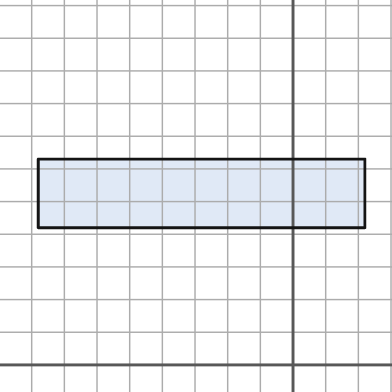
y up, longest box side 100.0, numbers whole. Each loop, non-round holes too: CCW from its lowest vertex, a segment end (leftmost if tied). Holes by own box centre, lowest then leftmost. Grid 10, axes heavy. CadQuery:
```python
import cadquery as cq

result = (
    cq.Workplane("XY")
    .moveTo(-78.0, 42.0)
    .lineTo(22.0, 42.0)
    .lineTo(22.0, 63.0)
    .lineTo(-78.0, 63.0)
    .close()
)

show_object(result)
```